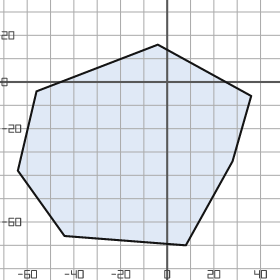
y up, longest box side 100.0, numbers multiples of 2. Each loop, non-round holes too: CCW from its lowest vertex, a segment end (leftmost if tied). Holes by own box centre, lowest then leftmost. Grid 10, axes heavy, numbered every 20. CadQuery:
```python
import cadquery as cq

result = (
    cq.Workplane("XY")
    .moveTo(8.0, -70.0)
    .lineTo(28.0, -34.0)
    .lineTo(36.0, -6.0)
    .lineTo(-4.0, 16.0)
    .lineTo(-56.0, -4.0)
    .lineTo(-64.0, -38.0)
    .lineTo(-44.0, -66.0)
    .close()
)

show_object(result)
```